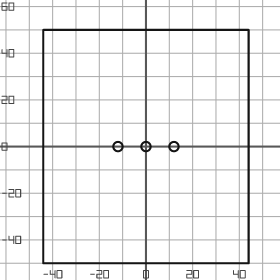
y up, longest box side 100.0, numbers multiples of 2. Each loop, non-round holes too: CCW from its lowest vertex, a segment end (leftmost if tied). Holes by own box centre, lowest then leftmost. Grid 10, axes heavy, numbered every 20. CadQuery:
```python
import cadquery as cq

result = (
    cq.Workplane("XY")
    .moveTo(-44.0, -50.0)
    .lineTo(44.0, -50.0)
    .lineTo(44.0, 50.0)
    .lineTo(-44.0, 50.0)
    .close()
    .moveTo(-12.0, 0.0)
    .circle(2.0)
    .moveTo(0.0, 0.0)
    .circle(2.0)
    .moveTo(12.0, 0.0)
    .circle(2.0)
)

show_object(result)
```